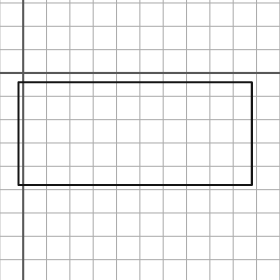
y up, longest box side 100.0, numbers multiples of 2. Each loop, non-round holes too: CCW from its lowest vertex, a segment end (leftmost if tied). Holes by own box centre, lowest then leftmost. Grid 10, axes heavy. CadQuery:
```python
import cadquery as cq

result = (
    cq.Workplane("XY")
    .moveTo(-2.0, -48.0)
    .lineTo(98.0, -48.0)
    .lineTo(98.0, -4.0)
    .lineTo(-2.0, -4.0)
    .close()
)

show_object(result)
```